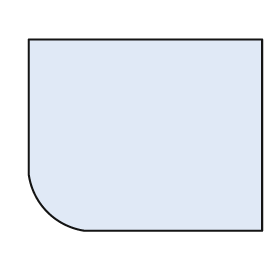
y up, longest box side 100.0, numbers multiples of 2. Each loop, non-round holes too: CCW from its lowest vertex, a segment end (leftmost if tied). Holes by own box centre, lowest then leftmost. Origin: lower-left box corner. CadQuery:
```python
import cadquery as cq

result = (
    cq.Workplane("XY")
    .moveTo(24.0, 0.0)
    .lineTo(100.0, 0.0)
    .lineTo(100.0, 82.0)
    .lineTo(0.0, 82.0)
    .lineTo(0.0, 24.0)
    .threePointArc((8.0, 8.0), (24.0, 0.0))
    .close()
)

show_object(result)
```